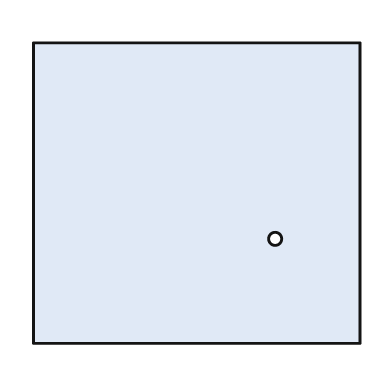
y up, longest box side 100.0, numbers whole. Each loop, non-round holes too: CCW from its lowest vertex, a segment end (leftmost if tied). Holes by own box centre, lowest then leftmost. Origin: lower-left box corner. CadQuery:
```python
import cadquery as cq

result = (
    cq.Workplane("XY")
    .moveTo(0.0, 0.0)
    .lineTo(100.0, 0.0)
    .lineTo(100.0, 92.0)
    .lineTo(0.0, 92.0)
    .close()
    .moveTo(74.0, 32.0)
    .circle(2.0)
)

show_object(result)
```